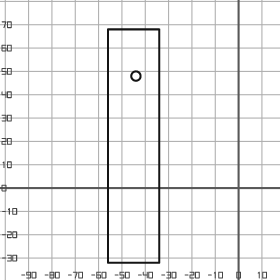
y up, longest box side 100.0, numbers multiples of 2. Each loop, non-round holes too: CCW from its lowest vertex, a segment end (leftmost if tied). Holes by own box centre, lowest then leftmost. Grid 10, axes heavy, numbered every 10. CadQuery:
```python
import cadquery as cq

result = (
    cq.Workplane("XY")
    .moveTo(-56.0, -32.0)
    .lineTo(-34.0, -32.0)
    .lineTo(-34.0, 68.0)
    .lineTo(-56.0, 68.0)
    .close()
    .moveTo(-44.0, 48.0)
    .circle(2.0)
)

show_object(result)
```